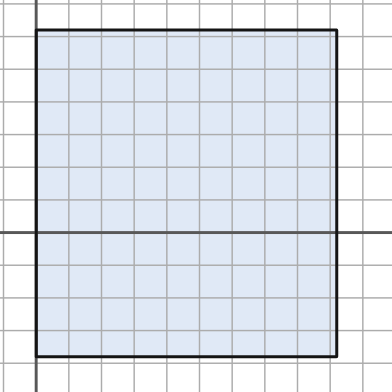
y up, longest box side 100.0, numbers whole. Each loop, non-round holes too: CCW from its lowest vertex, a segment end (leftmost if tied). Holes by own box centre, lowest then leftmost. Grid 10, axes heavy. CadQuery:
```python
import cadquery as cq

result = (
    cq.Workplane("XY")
    .moveTo(0.0, -38.0)
    .lineTo(92.0, -38.0)
    .lineTo(92.0, 62.0)
    .lineTo(0.0, 62.0)
    .close()
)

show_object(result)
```